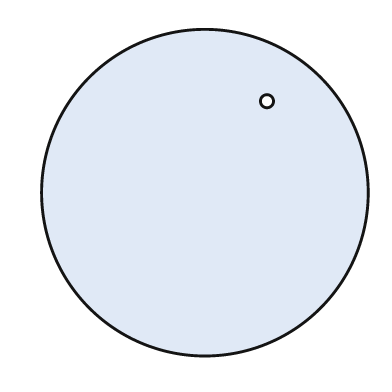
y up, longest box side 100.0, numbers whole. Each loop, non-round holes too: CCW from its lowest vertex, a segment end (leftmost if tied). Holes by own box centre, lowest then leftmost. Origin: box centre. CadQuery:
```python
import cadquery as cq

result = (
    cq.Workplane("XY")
    .moveTo(0.0, 0.0)
    .circle(50.0)
    .moveTo(19.0, 28.0)
    .circle(2.0)
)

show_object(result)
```